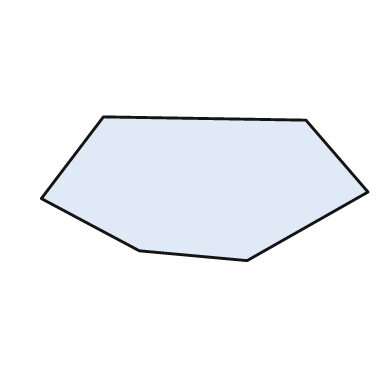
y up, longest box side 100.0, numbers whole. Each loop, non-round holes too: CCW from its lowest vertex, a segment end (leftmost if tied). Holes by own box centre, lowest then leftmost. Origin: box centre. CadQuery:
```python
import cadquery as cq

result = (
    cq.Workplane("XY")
    .moveTo(13.0, -22.0)
    .lineTo(50.0, -1.0)
    .lineTo(31.0, 21.0)
    .lineTo(-31.0, 22.0)
    .lineTo(-50.0, -3.0)
    .lineTo(-20.0, -19.0)
    .close()
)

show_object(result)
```